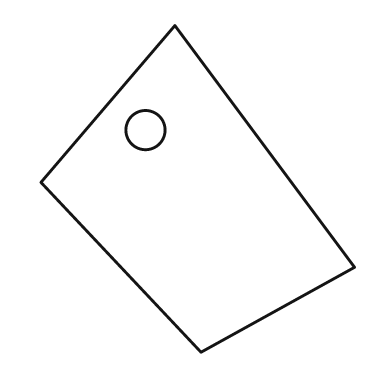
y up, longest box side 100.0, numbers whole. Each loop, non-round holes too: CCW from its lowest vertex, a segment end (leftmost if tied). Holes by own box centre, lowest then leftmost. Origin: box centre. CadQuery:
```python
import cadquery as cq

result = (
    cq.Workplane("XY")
    .moveTo(1.0, -50.0)
    .lineTo(48.0, -24.0)
    .lineTo(-7.0, 50.0)
    .lineTo(-48.0, 2.0)
    .close()
    .moveTo(-16.0, 18.0)
    .circle(6.0)
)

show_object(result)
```